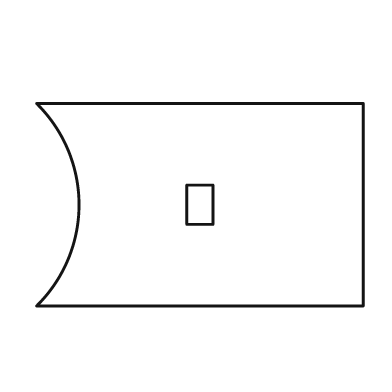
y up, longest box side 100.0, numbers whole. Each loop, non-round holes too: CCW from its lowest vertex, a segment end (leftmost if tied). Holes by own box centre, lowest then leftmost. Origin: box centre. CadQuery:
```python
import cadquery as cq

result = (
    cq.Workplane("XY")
    .moveTo(-50.0, -31.0)
    .lineTo(50.0, -31.0)
    .lineTo(50.0, 31.0)
    .lineTo(-50.0, 31.0)
    .threePointArc((-37.0, 0.0), (-50.0, -31.0))
    .close()
    .moveTo(-4.0, -6.0)
    .lineTo(4.0, -6.0)
    .lineTo(4.0, 6.0)
    .lineTo(-4.0, 6.0)
    .close()
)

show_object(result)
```